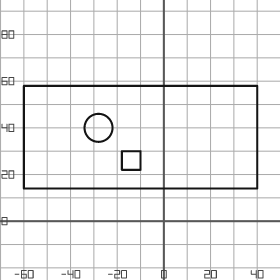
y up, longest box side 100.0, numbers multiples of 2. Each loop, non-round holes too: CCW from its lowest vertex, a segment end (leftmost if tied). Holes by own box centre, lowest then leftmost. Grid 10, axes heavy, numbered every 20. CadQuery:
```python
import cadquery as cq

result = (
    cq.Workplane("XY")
    .moveTo(-60.0, 14.0)
    .lineTo(40.0, 14.0)
    .lineTo(40.0, 58.0)
    .lineTo(-60.0, 58.0)
    .close()
    .moveTo(-18.0, 22.0)
    .lineTo(-10.0, 22.0)
    .lineTo(-10.0, 30.0)
    .lineTo(-18.0, 30.0)
    .close()
    .moveTo(-28.0, 40.0)
    .circle(6.0)
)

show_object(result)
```